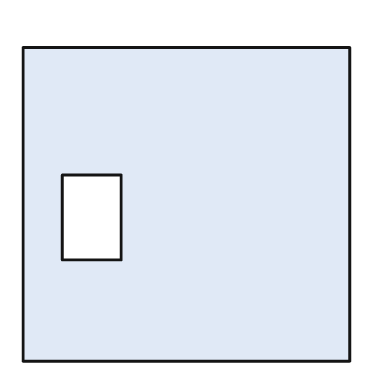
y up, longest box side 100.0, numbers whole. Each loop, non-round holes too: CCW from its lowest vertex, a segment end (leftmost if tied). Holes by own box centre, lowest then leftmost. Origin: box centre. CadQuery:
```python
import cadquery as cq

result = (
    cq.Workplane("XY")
    .moveTo(-50.0, -48.0)
    .lineTo(50.0, -48.0)
    .lineTo(50.0, 48.0)
    .lineTo(-50.0, 48.0)
    .close()
    .moveTo(-38.0, -17.0)
    .lineTo(-20.0, -17.0)
    .lineTo(-20.0, 9.0)
    .lineTo(-38.0, 9.0)
    .close()
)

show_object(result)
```